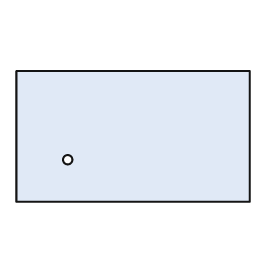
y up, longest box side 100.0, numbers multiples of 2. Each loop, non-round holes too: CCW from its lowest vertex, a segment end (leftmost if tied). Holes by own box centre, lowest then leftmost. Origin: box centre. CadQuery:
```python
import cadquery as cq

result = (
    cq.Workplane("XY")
    .moveTo(-50.0, -28.0)
    .lineTo(50.0, -28.0)
    .lineTo(50.0, 28.0)
    .lineTo(-50.0, 28.0)
    .close()
    .moveTo(-28.0, -10.0)
    .circle(2.0)
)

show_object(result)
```